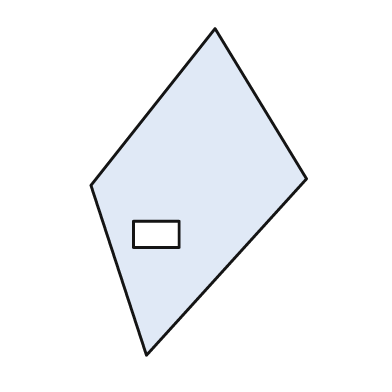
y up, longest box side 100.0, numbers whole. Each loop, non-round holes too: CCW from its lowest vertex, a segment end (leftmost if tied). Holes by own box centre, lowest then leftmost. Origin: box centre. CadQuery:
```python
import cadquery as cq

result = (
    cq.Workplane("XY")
    .moveTo(-16.0, -50.0)
    .lineTo(33.0, 4.0)
    .lineTo(5.0, 50.0)
    .lineTo(-33.0, 2.0)
    .close()
    .moveTo(-20.0, -17.0)
    .lineTo(-6.0, -17.0)
    .lineTo(-6.0, -9.0)
    .lineTo(-20.0, -9.0)
    .close()
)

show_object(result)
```